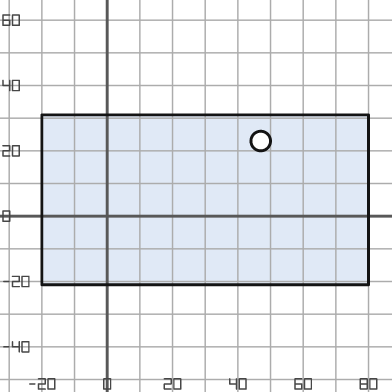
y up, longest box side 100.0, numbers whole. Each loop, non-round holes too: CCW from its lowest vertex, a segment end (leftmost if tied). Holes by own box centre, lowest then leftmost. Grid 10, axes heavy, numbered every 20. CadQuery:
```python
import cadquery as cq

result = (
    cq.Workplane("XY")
    .moveTo(-20.0, -21.0)
    .lineTo(80.0, -21.0)
    .lineTo(80.0, 31.0)
    .lineTo(-20.0, 31.0)
    .close()
    .moveTo(47.0, 23.0)
    .circle(3.0)
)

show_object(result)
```